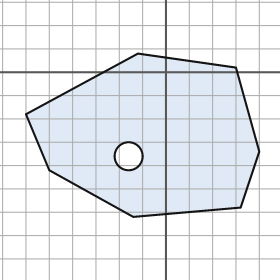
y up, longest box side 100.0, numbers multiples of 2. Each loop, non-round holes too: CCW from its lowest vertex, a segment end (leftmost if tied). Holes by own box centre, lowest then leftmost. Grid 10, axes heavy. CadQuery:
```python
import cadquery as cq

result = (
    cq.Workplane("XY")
    .moveTo(-14.0, -62.0)
    .lineTo(32.0, -58.0)
    .lineTo(40.0, -34.0)
    .lineTo(30.0, 2.0)
    .lineTo(-12.0, 8.0)
    .lineTo(-60.0, -18.0)
    .lineTo(-50.0, -42.0)
    .close()
    .moveTo(-16.0, -36.0)
    .circle(6.0)
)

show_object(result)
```